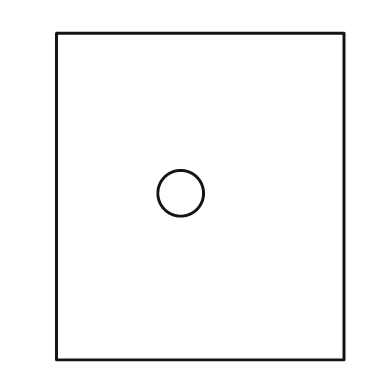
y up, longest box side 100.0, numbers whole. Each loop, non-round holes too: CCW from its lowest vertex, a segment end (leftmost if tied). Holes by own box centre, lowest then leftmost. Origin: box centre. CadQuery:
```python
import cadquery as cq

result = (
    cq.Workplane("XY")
    .moveTo(-44.0, -50.0)
    .lineTo(44.0, -50.0)
    .lineTo(44.0, 50.0)
    .lineTo(-44.0, 50.0)
    .close()
    .moveTo(-6.0, 1.0)
    .circle(7.0)
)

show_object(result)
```